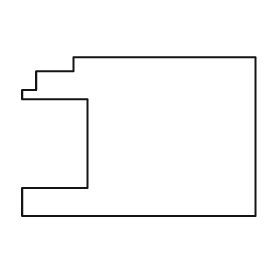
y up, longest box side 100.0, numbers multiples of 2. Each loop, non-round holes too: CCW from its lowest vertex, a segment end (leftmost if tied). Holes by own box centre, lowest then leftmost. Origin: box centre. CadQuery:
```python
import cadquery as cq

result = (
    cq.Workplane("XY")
    .moveTo(-50.0, -34.0)
    .lineTo(50.0, -34.0)
    .lineTo(50.0, 34.0)
    .lineTo(-28.0, 34.0)
    .lineTo(-28.0, 28.0)
    .lineTo(-44.0, 28.0)
    .lineTo(-44.0, 20.0)
    .lineTo(-50.0, 20.0)
    .lineTo(-50.0, 16.0)
    .lineTo(-22.0, 16.0)
    .lineTo(-22.0, -22.0)
    .lineTo(-50.0, -22.0)
    .close()
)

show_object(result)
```